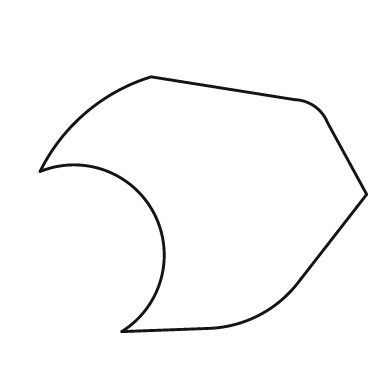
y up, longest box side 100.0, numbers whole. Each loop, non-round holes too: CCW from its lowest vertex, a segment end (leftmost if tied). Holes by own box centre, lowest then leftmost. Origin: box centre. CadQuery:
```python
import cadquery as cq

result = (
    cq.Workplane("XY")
    .moveTo(-25.0, -39.0)
    .lineTo(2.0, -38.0)
    .threePointArc((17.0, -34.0), (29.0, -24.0))
    .lineTo(50.0, 3.0)
    .lineTo(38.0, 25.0)
    .threePointArc((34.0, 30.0), (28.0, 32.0))
    .lineTo(-16.0, 39.0)
    .threePointArc((-36.0, 28.0), (-50.0, 10.0))
    .threePointArc((-15.0, -3.0), (-25.0, -39.0))
    .close()
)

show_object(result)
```